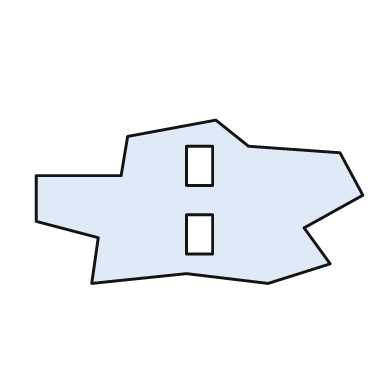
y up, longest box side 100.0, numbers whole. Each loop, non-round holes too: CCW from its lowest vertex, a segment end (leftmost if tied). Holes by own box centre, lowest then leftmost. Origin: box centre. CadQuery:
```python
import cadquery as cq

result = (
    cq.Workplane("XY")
    .moveTo(-33.0, -25.0)
    .lineTo(-4.0, -22.0)
    .lineTo(21.0, -25.0)
    .lineTo(40.0, -19.0)
    .lineTo(32.0, -8.0)
    .lineTo(50.0, 2.0)
    .lineTo(43.0, 15.0)
    .lineTo(15.0, 17.0)
    .lineTo(5.0, 25.0)
    .lineTo(-22.0, 20.0)
    .lineTo(-24.0, 8.0)
    .lineTo(-50.0, 8.0)
    .lineTo(-50.0, -6.0)
    .lineTo(-31.0, -11.0)
    .close()
    .moveTo(-4.0, -16.0)
    .lineTo(4.0, -16.0)
    .lineTo(4.0, -4.0)
    .lineTo(-4.0, -4.0)
    .close()
    .moveTo(-4.0, 5.0)
    .lineTo(4.0, 5.0)
    .lineTo(4.0, 17.0)
    .lineTo(-4.0, 17.0)
    .close()
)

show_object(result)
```